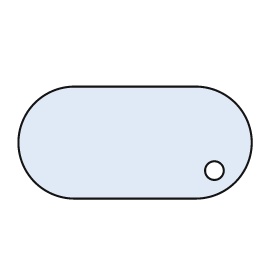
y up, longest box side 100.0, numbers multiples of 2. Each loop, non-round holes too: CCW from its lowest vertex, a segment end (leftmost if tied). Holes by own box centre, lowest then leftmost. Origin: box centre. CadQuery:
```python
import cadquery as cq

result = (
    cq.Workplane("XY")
    .moveTo(-26.0, -24.0)
    .lineTo(26.0, -24.0)
    .threePointArc((50.0, 0.0), (26.0, 24.0))
    .lineTo(-26.0, 24.0)
    .threePointArc((-50.0, 0.0), (-26.0, -24.0))
    .close()
    .moveTo(34.0, -12.0)
    .circle(4.0)
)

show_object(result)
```